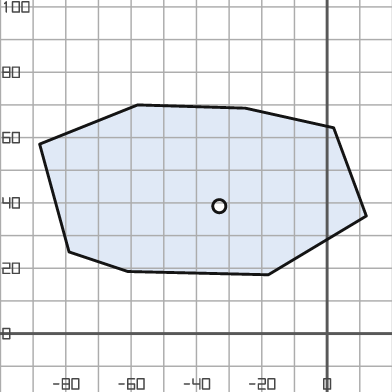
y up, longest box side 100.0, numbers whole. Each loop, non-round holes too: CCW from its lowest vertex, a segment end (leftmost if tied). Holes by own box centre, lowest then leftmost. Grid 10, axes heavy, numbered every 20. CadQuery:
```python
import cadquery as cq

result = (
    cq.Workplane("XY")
    .moveTo(-18.0, 18.0)
    .lineTo(12.0, 36.0)
    .lineTo(2.0, 63.0)
    .lineTo(-25.0, 69.0)
    .lineTo(-58.0, 70.0)
    .lineTo(-88.0, 58.0)
    .lineTo(-79.0, 25.0)
    .lineTo(-61.0, 19.0)
    .close()
    .moveTo(-33.0, 39.0)
    .circle(2.0)
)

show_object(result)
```